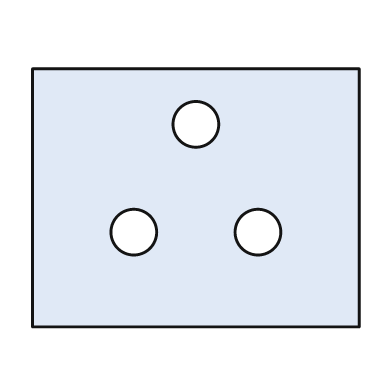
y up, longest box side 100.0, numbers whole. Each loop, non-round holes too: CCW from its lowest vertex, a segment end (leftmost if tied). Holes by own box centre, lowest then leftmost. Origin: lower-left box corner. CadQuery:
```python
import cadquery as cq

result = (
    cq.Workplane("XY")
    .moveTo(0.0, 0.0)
    .lineTo(100.0, 0.0)
    .lineTo(100.0, 79.0)
    .lineTo(0.0, 79.0)
    .close()
    .moveTo(31.0, 29.0)
    .circle(7.0)
    .moveTo(69.0, 29.0)
    .circle(7.0)
    .moveTo(50.0, 62.0)
    .circle(7.0)
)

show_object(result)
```